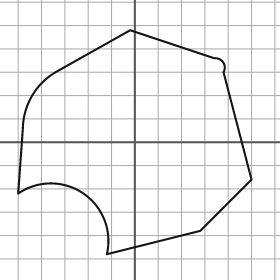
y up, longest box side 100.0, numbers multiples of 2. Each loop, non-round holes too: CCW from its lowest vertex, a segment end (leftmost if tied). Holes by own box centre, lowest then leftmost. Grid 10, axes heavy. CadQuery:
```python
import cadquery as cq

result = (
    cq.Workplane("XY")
    .moveTo(-12.0, -48.0)
    .lineTo(28.0, -38.0)
    .lineTo(50.0, -16.0)
    .lineTo(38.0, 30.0)
    .threePointArc((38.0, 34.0), (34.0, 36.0))
    .lineTo(-2.0, 48.0)
    .lineTo(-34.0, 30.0)
    .threePointArc((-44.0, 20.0), (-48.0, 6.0))
    .lineTo(-50.0, -22.0)
    .threePointArc((-22.0, -22.0), (-12.0, -48.0))
    .close()
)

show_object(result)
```